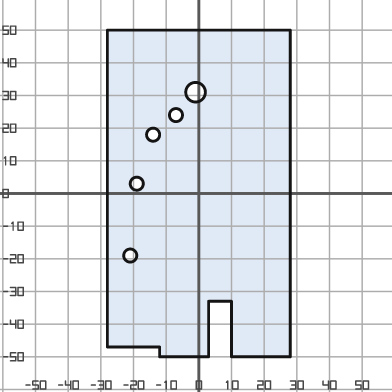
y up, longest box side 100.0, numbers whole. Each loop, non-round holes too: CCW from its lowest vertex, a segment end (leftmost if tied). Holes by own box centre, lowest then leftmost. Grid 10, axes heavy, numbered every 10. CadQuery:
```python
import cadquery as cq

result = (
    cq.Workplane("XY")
    .moveTo(-12.0, -50.0)
    .lineTo(3.0, -50.0)
    .lineTo(3.0, -33.0)
    .lineTo(10.0, -33.0)
    .lineTo(10.0, -50.0)
    .lineTo(28.0, -50.0)
    .lineTo(28.0, 50.0)
    .lineTo(-28.0, 50.0)
    .lineTo(-28.0, -47.0)
    .lineTo(-12.0, -47.0)
    .close()
    .moveTo(-21.0, -19.0)
    .circle(2.0)
    .moveTo(-19.0, 3.0)
    .circle(2.0)
    .moveTo(-14.0, 18.0)
    .circle(2.0)
    .moveTo(-7.0, 24.0)
    .circle(2.0)
    .moveTo(-1.0, 31.0)
    .circle(3.0)
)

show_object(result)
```